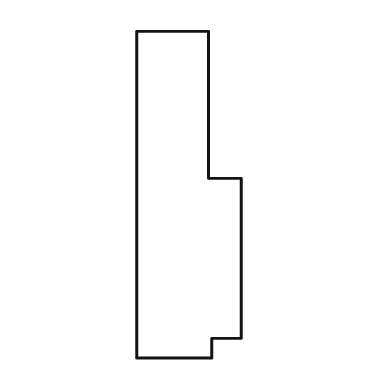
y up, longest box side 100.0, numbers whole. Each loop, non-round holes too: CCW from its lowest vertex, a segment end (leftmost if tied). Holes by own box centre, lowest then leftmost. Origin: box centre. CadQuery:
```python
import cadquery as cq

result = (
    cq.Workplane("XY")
    .moveTo(-16.0, -50.0)
    .lineTo(7.0, -50.0)
    .lineTo(7.0, -44.0)
    .lineTo(16.0, -44.0)
    .lineTo(16.0, 5.0)
    .lineTo(6.0, 5.0)
    .lineTo(6.0, 50.0)
    .lineTo(-16.0, 50.0)
    .close()
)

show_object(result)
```